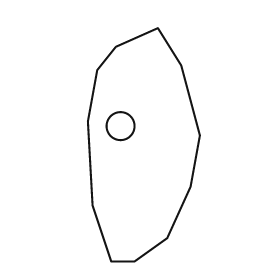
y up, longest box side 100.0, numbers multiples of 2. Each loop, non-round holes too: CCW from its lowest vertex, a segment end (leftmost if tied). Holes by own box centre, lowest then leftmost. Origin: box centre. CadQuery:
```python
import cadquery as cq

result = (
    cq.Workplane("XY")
    .moveTo(-14.0, -50.0)
    .lineTo(-4.0, -50.0)
    .lineTo(10.0, -40.0)
    .lineTo(20.0, -18.0)
    .lineTo(24.0, 4.0)
    .lineTo(16.0, 34.0)
    .lineTo(6.0, 50.0)
    .lineTo(-12.0, 42.0)
    .lineTo(-20.0, 32.0)
    .lineTo(-24.0, 10.0)
    .lineTo(-22.0, -26.0)
    .close()
    .moveTo(-10.0, 8.0)
    .circle(6.0)
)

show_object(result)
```